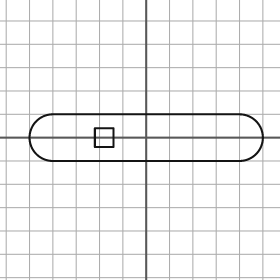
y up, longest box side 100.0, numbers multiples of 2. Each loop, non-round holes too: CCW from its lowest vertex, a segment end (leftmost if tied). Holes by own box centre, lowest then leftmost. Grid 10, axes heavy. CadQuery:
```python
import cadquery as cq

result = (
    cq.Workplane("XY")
    .moveTo(-40.0, -10.0)
    .lineTo(40.0, -10.0)
    .threePointArc((50.0, 0.0), (40.0, 10.0))
    .lineTo(-40.0, 10.0)
    .threePointArc((-50.0, 0.0), (-40.0, -10.0))
    .close()
    .moveTo(-22.0, -4.0)
    .lineTo(-14.0, -4.0)
    .lineTo(-14.0, 4.0)
    .lineTo(-22.0, 4.0)
    .close()
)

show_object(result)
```